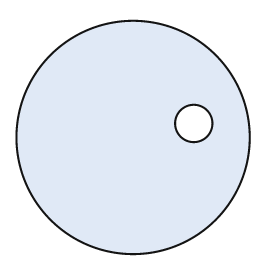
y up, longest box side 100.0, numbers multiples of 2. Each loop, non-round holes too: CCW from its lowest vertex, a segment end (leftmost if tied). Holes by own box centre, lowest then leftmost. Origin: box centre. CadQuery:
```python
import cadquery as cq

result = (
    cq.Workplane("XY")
    .moveTo(0.0, 0.0)
    .circle(50.0)
    .moveTo(26.0, 6.0)
    .circle(8.0)
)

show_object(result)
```